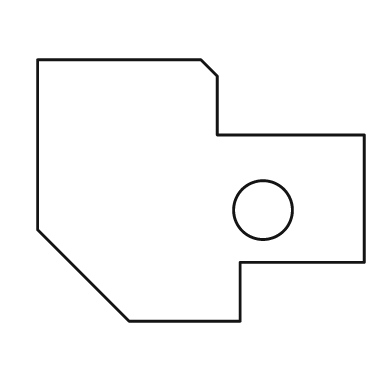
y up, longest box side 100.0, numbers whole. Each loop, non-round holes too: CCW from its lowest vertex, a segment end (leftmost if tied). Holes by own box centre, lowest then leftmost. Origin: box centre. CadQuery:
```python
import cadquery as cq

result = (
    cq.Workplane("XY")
    .moveTo(-22.0, -40.0)
    .lineTo(12.0, -40.0)
    .lineTo(12.0, -22.0)
    .lineTo(50.0, -22.0)
    .lineTo(50.0, 17.0)
    .lineTo(5.0, 17.0)
    .lineTo(5.0, 35.0)
    .lineTo(0.0, 40.0)
    .lineTo(-50.0, 40.0)
    .lineTo(-50.0, -12.0)
    .close()
    .moveTo(19.0, -6.0)
    .circle(9.0)
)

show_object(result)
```